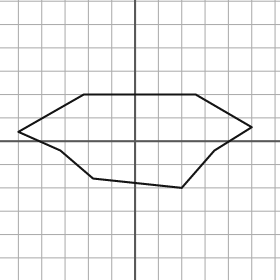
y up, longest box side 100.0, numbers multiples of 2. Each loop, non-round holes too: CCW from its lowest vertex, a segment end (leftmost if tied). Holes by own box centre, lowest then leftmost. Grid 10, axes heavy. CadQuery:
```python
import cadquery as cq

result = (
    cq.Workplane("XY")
    .moveTo(20.0, -20.0)
    .lineTo(34.0, -4.0)
    .lineTo(50.0, 6.0)
    .lineTo(26.0, 20.0)
    .lineTo(-22.0, 20.0)
    .lineTo(-50.0, 4.0)
    .lineTo(-32.0, -4.0)
    .lineTo(-18.0, -16.0)
    .close()
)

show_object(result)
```